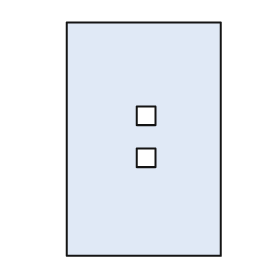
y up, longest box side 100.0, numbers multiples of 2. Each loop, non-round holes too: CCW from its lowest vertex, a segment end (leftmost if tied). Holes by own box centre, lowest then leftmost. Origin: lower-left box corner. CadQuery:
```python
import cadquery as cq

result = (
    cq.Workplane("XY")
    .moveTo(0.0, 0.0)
    .lineTo(66.0, 0.0)
    .lineTo(66.0, 100.0)
    .lineTo(0.0, 100.0)
    .close()
    .moveTo(30.0, 38.0)
    .lineTo(38.0, 38.0)
    .lineTo(38.0, 46.0)
    .lineTo(30.0, 46.0)
    .close()
    .moveTo(30.0, 56.0)
    .lineTo(38.0, 56.0)
    .lineTo(38.0, 64.0)
    .lineTo(30.0, 64.0)
    .close()
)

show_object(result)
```